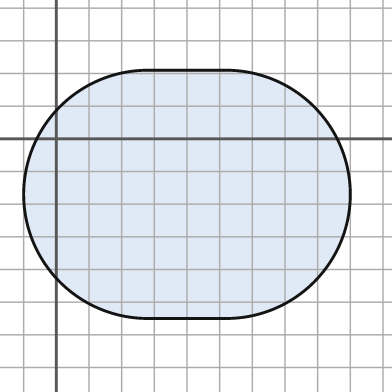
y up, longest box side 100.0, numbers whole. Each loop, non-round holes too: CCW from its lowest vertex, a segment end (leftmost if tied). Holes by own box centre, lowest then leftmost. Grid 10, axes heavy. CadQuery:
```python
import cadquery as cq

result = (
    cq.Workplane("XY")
    .moveTo(28.0, -55.0)
    .lineTo(52.0, -55.0)
    .threePointArc((90.0, -17.0), (52.0, 21.0))
    .lineTo(28.0, 21.0)
    .threePointArc((-10.0, -17.0), (28.0, -55.0))
    .close()
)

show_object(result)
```